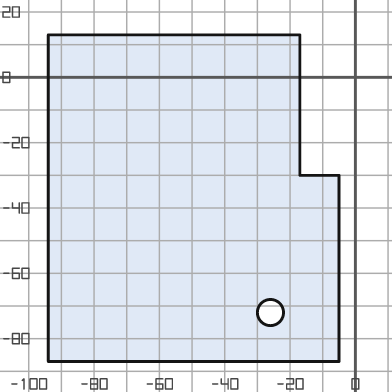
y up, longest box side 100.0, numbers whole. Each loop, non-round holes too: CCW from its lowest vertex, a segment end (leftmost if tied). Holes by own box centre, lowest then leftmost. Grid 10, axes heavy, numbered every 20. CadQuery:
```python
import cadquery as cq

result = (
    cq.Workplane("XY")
    .moveTo(-94.0, -87.0)
    .lineTo(-5.0, -87.0)
    .lineTo(-5.0, -30.0)
    .lineTo(-17.0, -30.0)
    .lineTo(-17.0, 13.0)
    .lineTo(-94.0, 13.0)
    .close()
    .moveTo(-26.0, -72.0)
    .circle(4.0)
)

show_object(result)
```